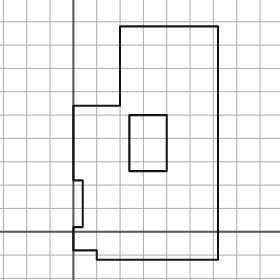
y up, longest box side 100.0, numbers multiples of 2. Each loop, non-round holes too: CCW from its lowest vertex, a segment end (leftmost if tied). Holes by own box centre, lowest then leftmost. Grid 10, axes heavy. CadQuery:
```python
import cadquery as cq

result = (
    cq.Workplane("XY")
    .moveTo(10.0, -12.0)
    .lineTo(62.0, -12.0)
    .lineTo(62.0, 88.0)
    .lineTo(20.0, 88.0)
    .lineTo(20.0, 54.0)
    .lineTo(0.0, 54.0)
    .lineTo(0.0, 22.0)
    .lineTo(4.0, 22.0)
    .lineTo(4.0, 2.0)
    .lineTo(0.0, 2.0)
    .lineTo(0.0, -8.0)
    .lineTo(10.0, -8.0)
    .close()
    .moveTo(24.0, 26.0)
    .lineTo(40.0, 26.0)
    .lineTo(40.0, 50.0)
    .lineTo(24.0, 50.0)
    .close()
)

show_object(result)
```